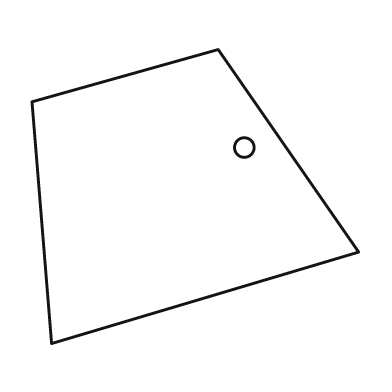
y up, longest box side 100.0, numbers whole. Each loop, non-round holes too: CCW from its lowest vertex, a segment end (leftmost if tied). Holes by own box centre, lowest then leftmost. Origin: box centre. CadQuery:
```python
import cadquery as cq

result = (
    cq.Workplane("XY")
    .moveTo(-44.0, -45.0)
    .lineTo(50.0, -17.0)
    .lineTo(7.0, 45.0)
    .lineTo(-50.0, 29.0)
    .close()
    .moveTo(15.0, 15.0)
    .circle(3.0)
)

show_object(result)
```